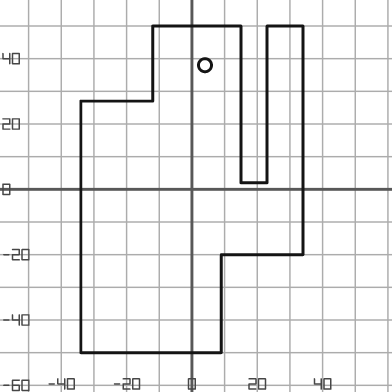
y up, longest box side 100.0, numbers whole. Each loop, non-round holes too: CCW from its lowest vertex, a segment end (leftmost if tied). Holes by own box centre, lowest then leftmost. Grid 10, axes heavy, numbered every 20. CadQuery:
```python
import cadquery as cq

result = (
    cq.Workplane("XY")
    .moveTo(-34.0, -50.0)
    .lineTo(9.0, -50.0)
    .lineTo(9.0, -20.0)
    .lineTo(34.0, -20.0)
    .lineTo(34.0, 50.0)
    .lineTo(23.0, 50.0)
    .lineTo(23.0, 2.0)
    .lineTo(15.0, 2.0)
    .lineTo(15.0, 50.0)
    .lineTo(-12.0, 50.0)
    .lineTo(-12.0, 27.0)
    .lineTo(-34.0, 27.0)
    .close()
    .moveTo(4.0, 38.0)
    .circle(2.0)
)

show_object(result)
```